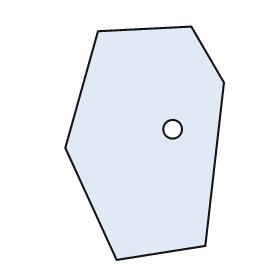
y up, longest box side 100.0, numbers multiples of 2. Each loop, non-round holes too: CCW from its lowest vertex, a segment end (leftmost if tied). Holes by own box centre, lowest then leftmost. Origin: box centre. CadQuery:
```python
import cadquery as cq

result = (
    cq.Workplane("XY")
    .moveTo(-12.0, -50.0)
    .lineTo(26.0, -44.0)
    .lineTo(34.0, 26.0)
    .lineTo(20.0, 50.0)
    .lineTo(-20.0, 48.0)
    .lineTo(-34.0, -2.0)
    .close()
    .moveTo(12.0, 6.0)
    .circle(4.0)
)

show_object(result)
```